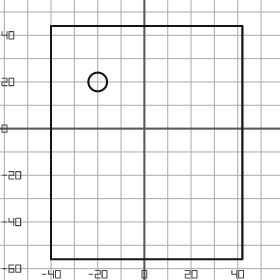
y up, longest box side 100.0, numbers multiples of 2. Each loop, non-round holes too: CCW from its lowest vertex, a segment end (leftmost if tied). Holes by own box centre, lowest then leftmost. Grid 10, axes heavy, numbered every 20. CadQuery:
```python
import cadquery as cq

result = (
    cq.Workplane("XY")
    .moveTo(-40.0, -56.0)
    .lineTo(42.0, -56.0)
    .lineTo(42.0, 44.0)
    .lineTo(-40.0, 44.0)
    .close()
    .moveTo(-20.0, 20.0)
    .circle(4.0)
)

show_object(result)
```